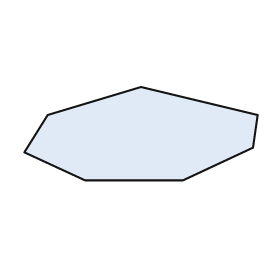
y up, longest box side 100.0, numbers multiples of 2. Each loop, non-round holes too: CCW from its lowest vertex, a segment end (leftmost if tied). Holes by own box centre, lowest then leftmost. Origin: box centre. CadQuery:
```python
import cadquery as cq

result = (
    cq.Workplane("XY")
    .moveTo(-24.0, -20.0)
    .lineTo(18.0, -20.0)
    .lineTo(48.0, -6.0)
    .lineTo(50.0, 8.0)
    .lineTo(0.0, 20.0)
    .lineTo(-40.0, 8.0)
    .lineTo(-50.0, -8.0)
    .close()
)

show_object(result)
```